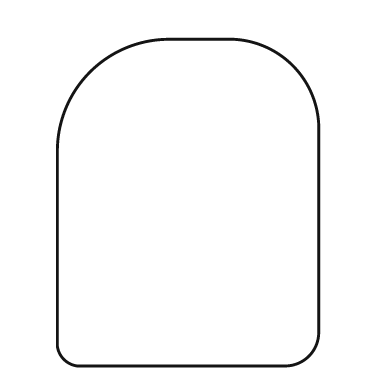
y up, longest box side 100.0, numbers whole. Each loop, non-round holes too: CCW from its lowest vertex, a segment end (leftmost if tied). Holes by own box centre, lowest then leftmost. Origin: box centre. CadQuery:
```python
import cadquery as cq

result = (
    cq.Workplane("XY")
    .moveTo(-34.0, -50.0)
    .lineTo(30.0, -50.0)
    .threePointArc((37.0, -47.0), (40.0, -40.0))
    .lineTo(40.0, 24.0)
    .threePointArc((32.0, 42.0), (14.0, 50.0))
    .lineTo(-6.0, 50.0)
    .threePointArc((-30.0, 40.0), (-40.0, 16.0))
    .lineTo(-40.0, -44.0)
    .threePointArc((-38.0, -48.0), (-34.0, -50.0))
    .close()
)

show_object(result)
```